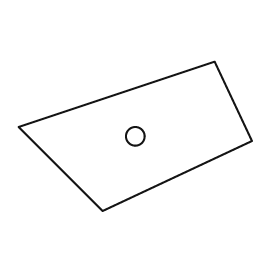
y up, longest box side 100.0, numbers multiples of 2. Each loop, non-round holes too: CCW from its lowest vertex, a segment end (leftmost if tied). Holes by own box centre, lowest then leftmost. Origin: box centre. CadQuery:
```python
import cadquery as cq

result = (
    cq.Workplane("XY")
    .moveTo(-14.0, -32.0)
    .lineTo(50.0, -2.0)
    .lineTo(34.0, 32.0)
    .lineTo(-50.0, 4.0)
    .close()
    .moveTo(0.0, 0.0)
    .circle(4.0)
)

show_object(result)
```